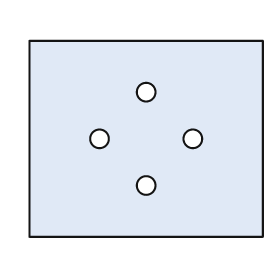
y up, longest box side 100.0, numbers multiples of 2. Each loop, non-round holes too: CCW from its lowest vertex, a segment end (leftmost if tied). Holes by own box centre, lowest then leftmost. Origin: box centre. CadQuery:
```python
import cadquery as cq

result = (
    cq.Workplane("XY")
    .moveTo(-50.0, -42.0)
    .lineTo(50.0, -42.0)
    .lineTo(50.0, 42.0)
    .lineTo(-50.0, 42.0)
    .close()
    .moveTo(0.0, -20.0)
    .circle(4.0)
    .moveTo(-20.0, 0.0)
    .circle(4.0)
    .moveTo(20.0, 0.0)
    .circle(4.0)
    .moveTo(0.0, 20.0)
    .circle(4.0)
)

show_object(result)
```